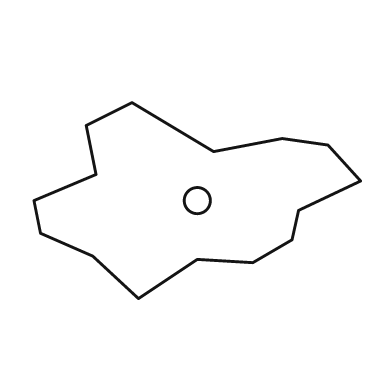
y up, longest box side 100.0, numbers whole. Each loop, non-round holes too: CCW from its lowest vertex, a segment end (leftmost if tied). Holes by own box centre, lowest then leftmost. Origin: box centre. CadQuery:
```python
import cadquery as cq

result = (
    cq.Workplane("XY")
    .moveTo(-18.0, -30.0)
    .lineTo(0.0, -18.0)
    .lineTo(17.0, -19.0)
    .lineTo(29.0, -12.0)
    .lineTo(31.0, -3.0)
    .lineTo(50.0, 6.0)
    .lineTo(40.0, 17.0)
    .lineTo(26.0, 19.0)
    .lineTo(5.0, 15.0)
    .lineTo(-20.0, 30.0)
    .lineTo(-34.0, 23.0)
    .lineTo(-31.0, 8.0)
    .lineTo(-50.0, 0.0)
    .lineTo(-48.0, -10.0)
    .lineTo(-32.0, -17.0)
    .close()
    .moveTo(0.0, 0.0)
    .circle(4.0)
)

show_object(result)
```